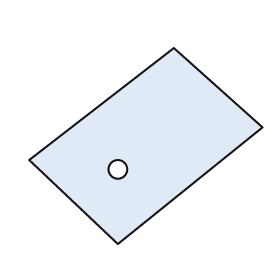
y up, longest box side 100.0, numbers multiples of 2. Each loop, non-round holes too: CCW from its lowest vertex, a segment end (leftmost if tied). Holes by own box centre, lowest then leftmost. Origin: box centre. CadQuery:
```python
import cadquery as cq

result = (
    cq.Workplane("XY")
    .moveTo(-12.0, -42.0)
    .lineTo(50.0, 8.0)
    .lineTo(12.0, 42.0)
    .lineTo(-50.0, -6.0)
    .close()
    .moveTo(-12.0, -10.0)
    .circle(4.0)
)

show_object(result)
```